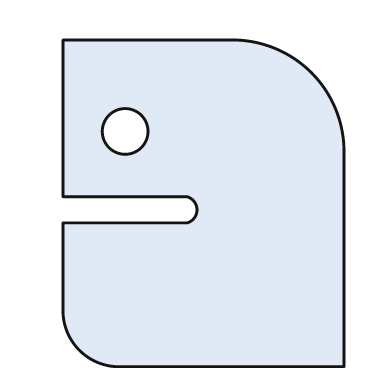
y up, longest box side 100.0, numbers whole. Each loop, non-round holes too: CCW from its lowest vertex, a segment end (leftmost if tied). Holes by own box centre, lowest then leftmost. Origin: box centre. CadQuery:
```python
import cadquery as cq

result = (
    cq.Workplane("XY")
    .moveTo(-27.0, -50.0)
    .lineTo(43.0, -50.0)
    .lineTo(43.0, 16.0)
    .threePointArc((33.0, 40.0), (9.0, 50.0))
    .lineTo(-43.0, 50.0)
    .lineTo(-43.0, 2.0)
    .lineTo(-5.0, 2.0)
    .threePointArc((-2.0, -2.0), (-5.0, -6.0))
    .lineTo(-43.0, -6.0)
    .lineTo(-43.0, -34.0)
    .threePointArc((-38.0, -45.0), (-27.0, -50.0))
    .close()
    .moveTo(-24.0, 22.0)
    .circle(7.0)
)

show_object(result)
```